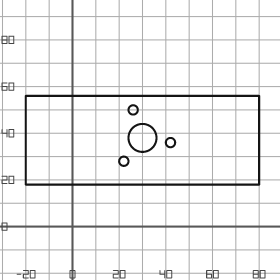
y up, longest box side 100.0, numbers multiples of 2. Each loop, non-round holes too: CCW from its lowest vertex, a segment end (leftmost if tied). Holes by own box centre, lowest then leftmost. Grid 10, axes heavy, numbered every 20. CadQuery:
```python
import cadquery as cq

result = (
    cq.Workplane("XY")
    .moveTo(-20.0, 18.0)
    .lineTo(80.0, 18.0)
    .lineTo(80.0, 56.0)
    .lineTo(-20.0, 56.0)
    .close()
    .moveTo(22.0, 28.0)
    .circle(2.0)
    .moveTo(42.0, 36.0)
    .circle(2.0)
    .moveTo(30.0, 38.0)
    .circle(6.0)
    .moveTo(26.0, 50.0)
    .circle(2.0)
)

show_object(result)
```